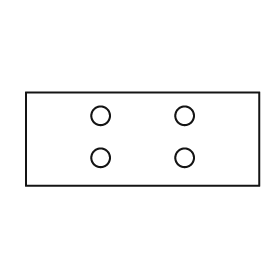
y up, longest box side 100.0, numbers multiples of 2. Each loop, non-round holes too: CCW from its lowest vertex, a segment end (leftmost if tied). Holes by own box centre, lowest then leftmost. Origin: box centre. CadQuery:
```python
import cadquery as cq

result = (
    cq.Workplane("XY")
    .moveTo(-50.0, -20.0)
    .lineTo(50.0, -20.0)
    .lineTo(50.0, 20.0)
    .lineTo(-50.0, 20.0)
    .close()
    .moveTo(-18.0, -8.0)
    .circle(4.0)
    .moveTo(18.0, -8.0)
    .circle(4.0)
    .moveTo(-18.0, 10.0)
    .circle(4.0)
    .moveTo(18.0, 10.0)
    .circle(4.0)
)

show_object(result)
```